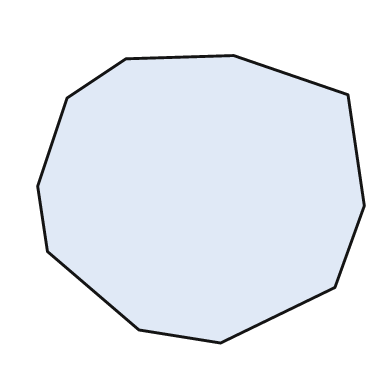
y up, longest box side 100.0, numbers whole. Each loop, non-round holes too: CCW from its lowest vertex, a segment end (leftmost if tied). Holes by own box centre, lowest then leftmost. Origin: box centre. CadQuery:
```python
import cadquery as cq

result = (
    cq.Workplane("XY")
    .moveTo(6.0, -44.0)
    .lineTo(41.0, -27.0)
    .lineTo(50.0, -2.0)
    .lineTo(45.0, 32.0)
    .lineTo(10.0, 44.0)
    .lineTo(-23.0, 43.0)
    .lineTo(-41.0, 31.0)
    .lineTo(-50.0, 4.0)
    .lineTo(-47.0, -16.0)
    .lineTo(-19.0, -40.0)
    .close()
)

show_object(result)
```